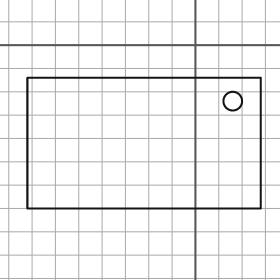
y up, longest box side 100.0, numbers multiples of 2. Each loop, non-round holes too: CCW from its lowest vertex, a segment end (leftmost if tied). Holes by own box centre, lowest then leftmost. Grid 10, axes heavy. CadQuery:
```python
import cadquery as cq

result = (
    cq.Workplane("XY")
    .moveTo(-72.0, -70.0)
    .lineTo(28.0, -70.0)
    .lineTo(28.0, -14.0)
    .lineTo(-72.0, -14.0)
    .close()
    .moveTo(16.0, -24.0)
    .circle(4.0)
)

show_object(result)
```